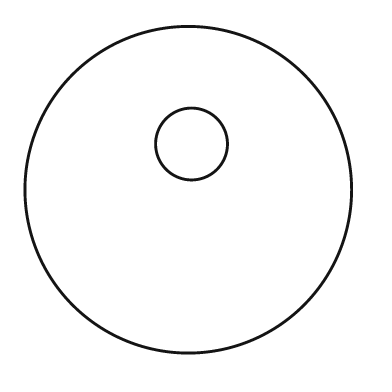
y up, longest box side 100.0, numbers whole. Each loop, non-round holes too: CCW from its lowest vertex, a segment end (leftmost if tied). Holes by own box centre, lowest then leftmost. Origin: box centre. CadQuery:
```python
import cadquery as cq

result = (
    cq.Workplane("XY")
    .moveTo(0.0, 0.0)
    .circle(50.0)
    .moveTo(1.0, 14.0)
    .circle(11.0)
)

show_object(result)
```